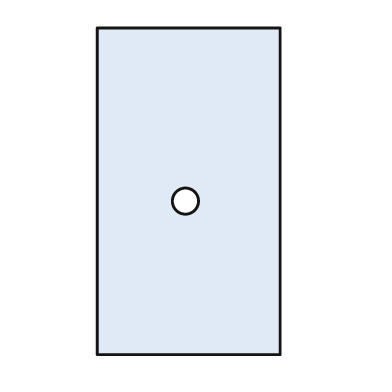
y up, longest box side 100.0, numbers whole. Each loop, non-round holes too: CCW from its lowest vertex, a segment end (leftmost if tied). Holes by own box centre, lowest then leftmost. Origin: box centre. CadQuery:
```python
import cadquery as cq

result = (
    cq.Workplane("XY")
    .moveTo(-28.0, -50.0)
    .lineTo(28.0, -50.0)
    .lineTo(28.0, 50.0)
    .lineTo(-28.0, 50.0)
    .close()
    .moveTo(-1.0, -3.0)
    .circle(4.0)
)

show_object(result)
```